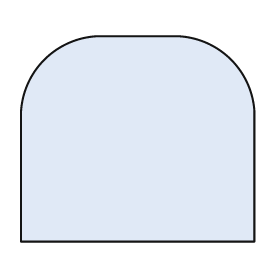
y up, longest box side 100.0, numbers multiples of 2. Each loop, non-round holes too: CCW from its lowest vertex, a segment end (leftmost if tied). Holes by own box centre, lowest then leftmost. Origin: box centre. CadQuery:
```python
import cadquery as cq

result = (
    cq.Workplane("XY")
    .moveTo(-50.0, -44.0)
    .lineTo(50.0, -44.0)
    .lineTo(50.0, 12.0)
    .threePointArc((40.0, 34.0), (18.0, 44.0))
    .lineTo(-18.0, 44.0)
    .threePointArc((-40.0, 34.0), (-50.0, 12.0))
    .close()
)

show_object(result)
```